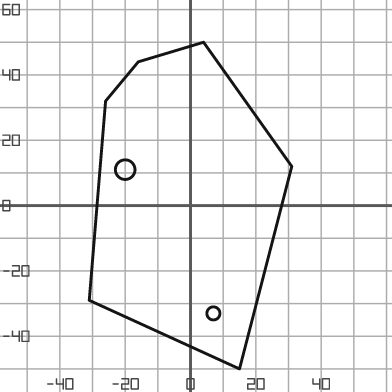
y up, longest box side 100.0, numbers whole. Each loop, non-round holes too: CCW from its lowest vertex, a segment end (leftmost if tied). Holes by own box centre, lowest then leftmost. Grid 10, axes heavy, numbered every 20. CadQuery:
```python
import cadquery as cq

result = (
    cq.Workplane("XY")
    .moveTo(15.0, -50.0)
    .lineTo(31.0, 12.0)
    .lineTo(4.0, 50.0)
    .lineTo(-16.0, 44.0)
    .lineTo(-26.0, 32.0)
    .lineTo(-31.0, -29.0)
    .close()
    .moveTo(7.0, -33.0)
    .circle(2.0)
    .moveTo(-20.0, 11.0)
    .circle(3.0)
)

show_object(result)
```